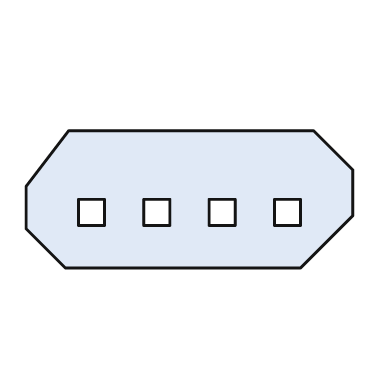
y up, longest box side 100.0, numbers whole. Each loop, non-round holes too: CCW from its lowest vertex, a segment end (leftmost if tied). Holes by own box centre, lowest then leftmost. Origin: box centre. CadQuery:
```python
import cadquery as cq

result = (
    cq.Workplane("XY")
    .moveTo(-38.0, -21.0)
    .lineTo(34.0, -21.0)
    .lineTo(50.0, -5.0)
    .lineTo(50.0, 9.0)
    .lineTo(38.0, 21.0)
    .lineTo(-37.0, 21.0)
    .lineTo(-50.0, 4.0)
    .lineTo(-50.0, -9.0)
    .close()
    .moveTo(-34.0, -8.0)
    .lineTo(-26.0, -8.0)
    .lineTo(-26.0, 0.0)
    .lineTo(-34.0, 0.0)
    .close()
    .moveTo(-14.0, -8.0)
    .lineTo(-6.0, -8.0)
    .lineTo(-6.0, 0.0)
    .lineTo(-14.0, 0.0)
    .close()
    .moveTo(6.0, -8.0)
    .lineTo(14.0, -8.0)
    .lineTo(14.0, 0.0)
    .lineTo(6.0, 0.0)
    .close()
    .moveTo(26.0, -8.0)
    .lineTo(34.0, -8.0)
    .lineTo(34.0, 0.0)
    .lineTo(26.0, 0.0)
    .close()
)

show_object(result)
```